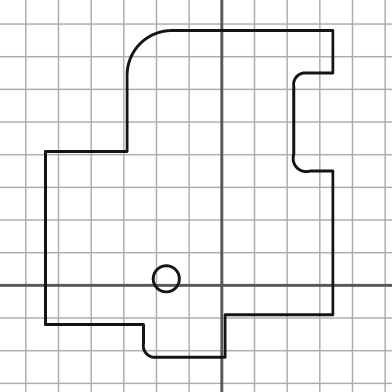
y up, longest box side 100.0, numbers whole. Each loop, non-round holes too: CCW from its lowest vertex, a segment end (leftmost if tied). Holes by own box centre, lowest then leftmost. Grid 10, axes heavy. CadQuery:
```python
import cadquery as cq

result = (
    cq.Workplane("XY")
    .moveTo(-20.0, -22.0)
    .lineTo(1.0, -22.0)
    .lineTo(1.0, -9.0)
    .lineTo(34.0, -9.0)
    .lineTo(34.0, 35.0)
    .lineTo(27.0, 35.0)
    .threePointArc((23.0, 36.0), (22.0, 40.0))
    .lineTo(22.0, 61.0)
    .threePointArc((23.0, 64.0), (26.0, 65.0))
    .lineTo(34.0, 65.0)
    .lineTo(34.0, 78.0)
    .lineTo(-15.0, 78.0)
    .threePointArc((-25.0, 74.0), (-29.0, 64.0))
    .lineTo(-29.0, 41.0)
    .lineTo(-54.0, 41.0)
    .lineTo(-54.0, -12.0)
    .lineTo(-24.0, -12.0)
    .lineTo(-24.0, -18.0)
    .threePointArc((-23.0, -21.0), (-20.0, -22.0))
    .close()
    .moveTo(-17.0, 2.0)
    .circle(4.0)
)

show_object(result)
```